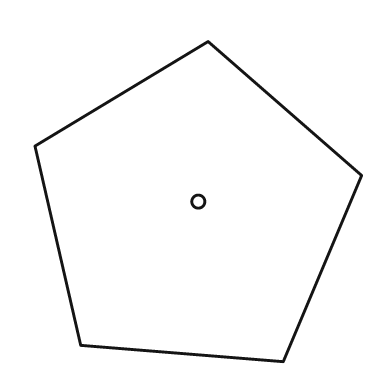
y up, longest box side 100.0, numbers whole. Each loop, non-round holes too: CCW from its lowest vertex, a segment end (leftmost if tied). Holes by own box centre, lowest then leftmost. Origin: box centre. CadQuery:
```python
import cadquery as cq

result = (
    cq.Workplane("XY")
    .moveTo(26.0, -49.0)
    .lineTo(50.0, 8.0)
    .lineTo(3.0, 49.0)
    .lineTo(-50.0, 17.0)
    .lineTo(-36.0, -44.0)
    .close()
    .moveTo(0.0, 0.0)
    .circle(2.0)
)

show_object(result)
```